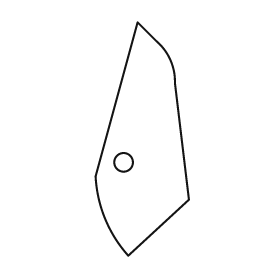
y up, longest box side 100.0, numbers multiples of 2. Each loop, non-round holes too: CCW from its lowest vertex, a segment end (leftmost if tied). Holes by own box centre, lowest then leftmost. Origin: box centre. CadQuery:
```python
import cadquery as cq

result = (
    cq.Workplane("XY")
    .moveTo(-6.0, -50.0)
    .lineTo(20.0, -26.0)
    .lineTo(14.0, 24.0)
    .threePointArc((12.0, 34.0), (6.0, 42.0))
    .lineTo(-2.0, 50.0)
    .lineTo(-20.0, -16.0)
    .threePointArc((-16.0, -34.0), (-6.0, -50.0))
    .close()
    .moveTo(-8.0, -10.0)
    .circle(4.0)
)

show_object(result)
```